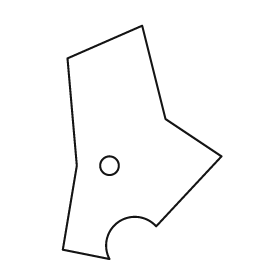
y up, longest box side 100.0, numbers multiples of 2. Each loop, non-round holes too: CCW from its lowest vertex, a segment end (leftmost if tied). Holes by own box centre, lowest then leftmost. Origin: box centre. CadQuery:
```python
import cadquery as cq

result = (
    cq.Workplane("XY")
    .moveTo(-14.0, -50.0)
    .threePointArc((-10.0, -34.0), (6.0, -36.0))
    .lineTo(34.0, -6.0)
    .lineTo(10.0, 10.0)
    .lineTo(0.0, 50.0)
    .lineTo(-32.0, 36.0)
    .lineTo(-28.0, -10.0)
    .lineTo(-34.0, -46.0)
    .close()
    .moveTo(-14.0, -10.0)
    .circle(4.0)
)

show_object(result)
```